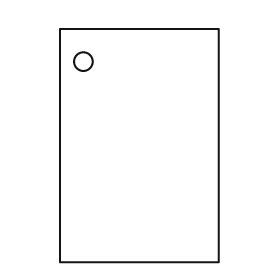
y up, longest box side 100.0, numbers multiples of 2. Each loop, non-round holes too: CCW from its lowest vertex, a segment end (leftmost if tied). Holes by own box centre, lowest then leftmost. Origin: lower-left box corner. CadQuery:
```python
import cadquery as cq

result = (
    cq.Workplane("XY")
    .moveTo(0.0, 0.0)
    .lineTo(68.0, 0.0)
    .lineTo(68.0, 100.0)
    .lineTo(0.0, 100.0)
    .close()
    .moveTo(10.0, 86.0)
    .circle(4.0)
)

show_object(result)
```